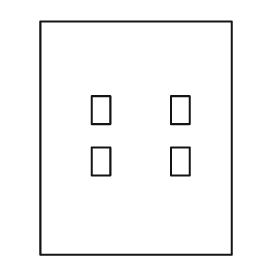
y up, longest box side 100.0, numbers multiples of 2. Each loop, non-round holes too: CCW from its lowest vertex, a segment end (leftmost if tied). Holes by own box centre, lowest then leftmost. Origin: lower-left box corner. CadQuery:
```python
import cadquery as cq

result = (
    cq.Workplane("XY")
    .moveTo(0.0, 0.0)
    .lineTo(82.0, 0.0)
    .lineTo(82.0, 100.0)
    .lineTo(0.0, 100.0)
    .close()
    .moveTo(22.0, 34.0)
    .lineTo(30.0, 34.0)
    .lineTo(30.0, 46.0)
    .lineTo(22.0, 46.0)
    .close()
    .moveTo(56.0, 34.0)
    .lineTo(64.0, 34.0)
    .lineTo(64.0, 46.0)
    .lineTo(56.0, 46.0)
    .close()
    .moveTo(22.0, 56.0)
    .lineTo(30.0, 56.0)
    .lineTo(30.0, 68.0)
    .lineTo(22.0, 68.0)
    .close()
    .moveTo(56.0, 56.0)
    .lineTo(64.0, 56.0)
    .lineTo(64.0, 68.0)
    .lineTo(56.0, 68.0)
    .close()
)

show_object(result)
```